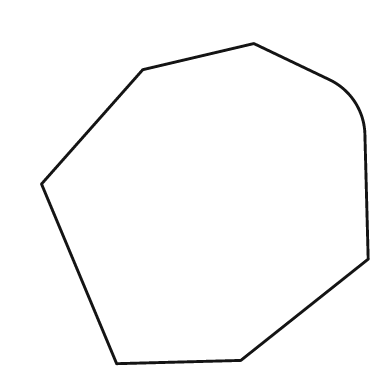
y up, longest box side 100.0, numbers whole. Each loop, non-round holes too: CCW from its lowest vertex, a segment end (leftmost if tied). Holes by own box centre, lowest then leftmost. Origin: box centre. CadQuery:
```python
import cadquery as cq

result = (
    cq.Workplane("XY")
    .moveTo(-27.0, -49.0)
    .lineTo(11.0, -48.0)
    .lineTo(50.0, -17.0)
    .lineTo(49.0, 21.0)
    .threePointArc((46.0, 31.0), (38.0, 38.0))
    .lineTo(15.0, 49.0)
    .lineTo(-19.0, 41.0)
    .lineTo(-50.0, 6.0)
    .close()
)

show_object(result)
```